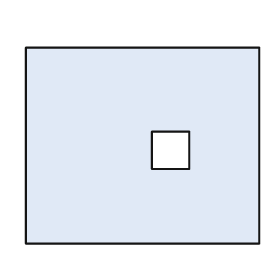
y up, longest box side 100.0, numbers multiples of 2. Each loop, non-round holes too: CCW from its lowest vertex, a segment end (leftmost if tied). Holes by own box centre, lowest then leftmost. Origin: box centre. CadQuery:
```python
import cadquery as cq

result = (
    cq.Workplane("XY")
    .moveTo(-50.0, -42.0)
    .lineTo(50.0, -42.0)
    .lineTo(50.0, 42.0)
    .lineTo(-50.0, 42.0)
    .close()
    .moveTo(4.0, -10.0)
    .lineTo(20.0, -10.0)
    .lineTo(20.0, 6.0)
    .lineTo(4.0, 6.0)
    .close()
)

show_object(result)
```